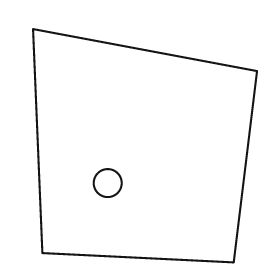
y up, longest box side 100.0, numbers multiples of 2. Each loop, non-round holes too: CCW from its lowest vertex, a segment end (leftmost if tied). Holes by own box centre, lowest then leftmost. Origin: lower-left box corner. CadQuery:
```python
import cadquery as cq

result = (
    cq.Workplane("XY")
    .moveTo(86.0, 0.0)
    .lineTo(96.0, 82.0)
    .lineTo(0.0, 100.0)
    .lineTo(4.0, 4.0)
    .close()
    .moveTo(32.0, 34.0)
    .circle(6.0)
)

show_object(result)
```